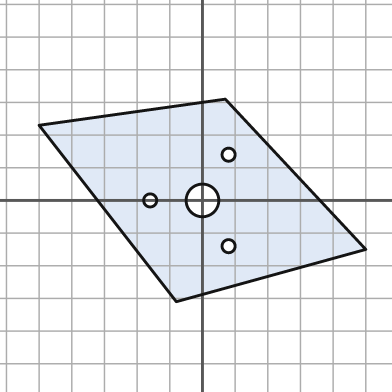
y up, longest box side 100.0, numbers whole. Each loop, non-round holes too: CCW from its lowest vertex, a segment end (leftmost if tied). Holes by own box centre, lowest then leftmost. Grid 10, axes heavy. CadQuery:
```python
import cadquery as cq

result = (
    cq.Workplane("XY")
    .moveTo(-8.0, -31.0)
    .lineTo(50.0, -15.0)
    .lineTo(7.0, 31.0)
    .lineTo(-50.0, 23.0)
    .close()
    .moveTo(8.0, -14.0)
    .circle(2.0)
    .moveTo(-16.0, 0.0)
    .circle(2.0)
    .moveTo(0.0, 0.0)
    .circle(5.0)
    .moveTo(8.0, 14.0)
    .circle(2.0)
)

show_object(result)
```